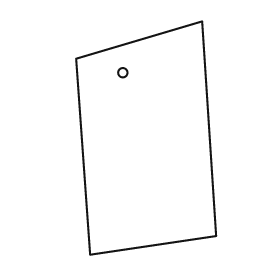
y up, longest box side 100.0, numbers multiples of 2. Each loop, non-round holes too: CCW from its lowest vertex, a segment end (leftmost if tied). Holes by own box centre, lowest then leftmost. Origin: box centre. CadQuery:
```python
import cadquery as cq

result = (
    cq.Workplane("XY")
    .moveTo(-24.0, -50.0)
    .lineTo(30.0, -42.0)
    .lineTo(24.0, 50.0)
    .lineTo(-30.0, 34.0)
    .close()
    .moveTo(-10.0, 28.0)
    .circle(2.0)
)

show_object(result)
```